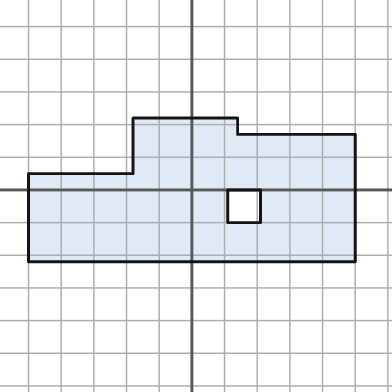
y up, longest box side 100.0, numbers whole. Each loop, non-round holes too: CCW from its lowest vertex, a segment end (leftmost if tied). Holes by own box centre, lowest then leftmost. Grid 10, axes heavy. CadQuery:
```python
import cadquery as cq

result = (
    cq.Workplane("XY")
    .moveTo(-50.0, -22.0)
    .lineTo(50.0, -22.0)
    .lineTo(50.0, 17.0)
    .lineTo(14.0, 17.0)
    .lineTo(14.0, 22.0)
    .lineTo(-18.0, 22.0)
    .lineTo(-18.0, 5.0)
    .lineTo(-50.0, 5.0)
    .close()
    .moveTo(11.0, -10.0)
    .lineTo(21.0, -10.0)
    .lineTo(21.0, 0.0)
    .lineTo(11.0, 0.0)
    .close()
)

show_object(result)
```